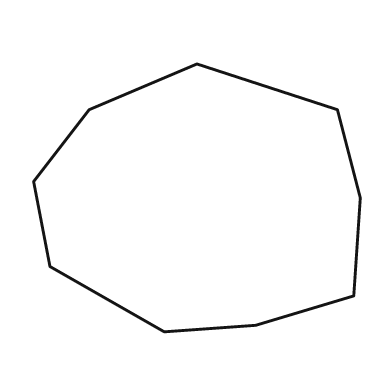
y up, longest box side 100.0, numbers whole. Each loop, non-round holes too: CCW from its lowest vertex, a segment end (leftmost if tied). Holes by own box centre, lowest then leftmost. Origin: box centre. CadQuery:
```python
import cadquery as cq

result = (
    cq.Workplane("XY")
    .moveTo(-10.0, -41.0)
    .lineTo(18.0, -39.0)
    .lineTo(48.0, -30.0)
    .lineTo(50.0, 0.0)
    .lineTo(43.0, 27.0)
    .lineTo(0.0, 41.0)
    .lineTo(-33.0, 27.0)
    .lineTo(-50.0, 5.0)
    .lineTo(-45.0, -21.0)
    .close()
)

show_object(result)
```